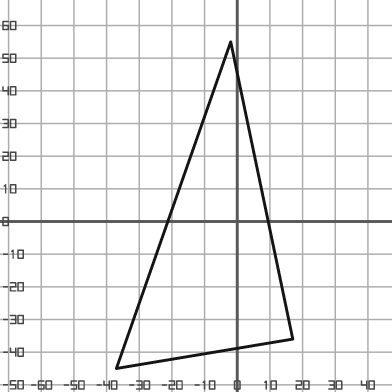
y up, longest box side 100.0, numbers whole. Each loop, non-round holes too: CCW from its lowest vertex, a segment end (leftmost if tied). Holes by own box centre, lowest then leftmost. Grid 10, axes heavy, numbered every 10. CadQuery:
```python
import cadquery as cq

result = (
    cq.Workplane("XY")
    .moveTo(-37.0, -45.0)
    .lineTo(17.0, -36.0)
    .lineTo(-2.0, 55.0)
    .close()
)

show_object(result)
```